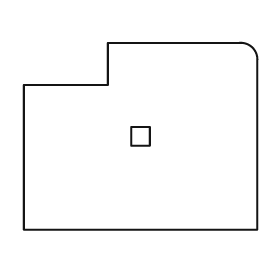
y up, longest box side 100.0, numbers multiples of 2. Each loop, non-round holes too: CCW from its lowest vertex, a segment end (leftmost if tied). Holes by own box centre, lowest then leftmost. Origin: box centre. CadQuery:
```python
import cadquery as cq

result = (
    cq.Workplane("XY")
    .moveTo(-50.0, -40.0)
    .lineTo(50.0, -40.0)
    .lineTo(50.0, 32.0)
    .threePointArc((48.0, 38.0), (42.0, 40.0))
    .lineTo(-14.0, 40.0)
    .lineTo(-14.0, 22.0)
    .lineTo(-50.0, 22.0)
    .close()
    .moveTo(-4.0, -4.0)
    .lineTo(4.0, -4.0)
    .lineTo(4.0, 4.0)
    .lineTo(-4.0, 4.0)
    .close()
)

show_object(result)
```